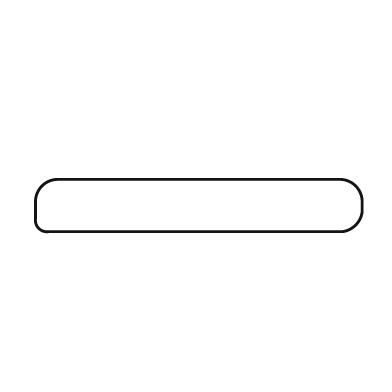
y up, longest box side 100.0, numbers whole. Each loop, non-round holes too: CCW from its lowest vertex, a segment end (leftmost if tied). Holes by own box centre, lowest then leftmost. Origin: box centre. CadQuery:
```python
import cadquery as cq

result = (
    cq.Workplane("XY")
    .moveTo(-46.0, -8.0)
    .lineTo(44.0, -8.0)
    .threePointArc((48.0, -6.0), (50.0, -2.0))
    .lineTo(50.0, 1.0)
    .threePointArc((48.0, 6.0), (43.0, 8.0))
    .lineTo(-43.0, 8.0)
    .threePointArc((-48.0, 6.0), (-50.0, 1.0))
    .lineTo(-50.0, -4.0)
    .threePointArc((-49.0, -7.0), (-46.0, -8.0))
    .close()
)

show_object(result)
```